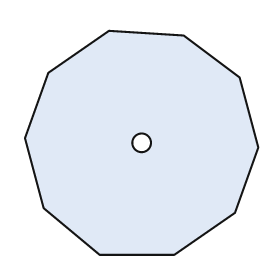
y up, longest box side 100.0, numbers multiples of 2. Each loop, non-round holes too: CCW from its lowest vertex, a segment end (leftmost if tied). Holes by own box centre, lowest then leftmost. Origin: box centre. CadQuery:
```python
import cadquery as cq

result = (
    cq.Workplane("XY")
    .moveTo(-18.0, -48.0)
    .lineTo(14.0, -48.0)
    .lineTo(40.0, -30.0)
    .lineTo(50.0, -2.0)
    .lineTo(42.0, 28.0)
    .lineTo(18.0, 46.0)
    .lineTo(-14.0, 48.0)
    .lineTo(-40.0, 30.0)
    .lineTo(-50.0, 2.0)
    .lineTo(-42.0, -28.0)
    .close()
    .moveTo(0.0, 0.0)
    .circle(4.0)
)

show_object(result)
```